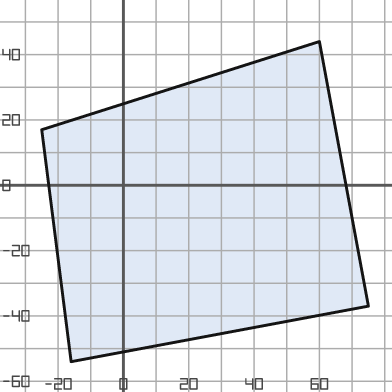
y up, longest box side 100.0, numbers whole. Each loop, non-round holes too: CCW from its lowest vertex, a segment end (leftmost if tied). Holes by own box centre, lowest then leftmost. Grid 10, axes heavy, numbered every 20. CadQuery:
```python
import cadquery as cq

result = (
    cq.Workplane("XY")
    .moveTo(-16.0, -54.0)
    .lineTo(75.0, -37.0)
    .lineTo(60.0, 44.0)
    .lineTo(-25.0, 17.0)
    .close()
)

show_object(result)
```